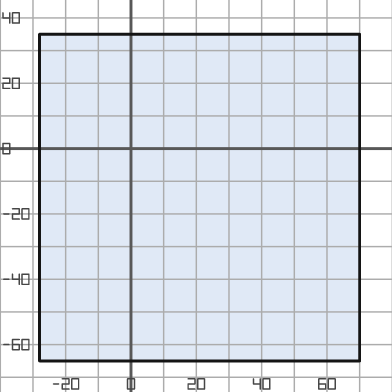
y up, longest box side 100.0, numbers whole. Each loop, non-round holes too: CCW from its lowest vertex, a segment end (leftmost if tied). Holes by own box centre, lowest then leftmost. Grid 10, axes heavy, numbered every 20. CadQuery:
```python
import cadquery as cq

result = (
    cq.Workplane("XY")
    .moveTo(-28.0, -65.0)
    .lineTo(70.0, -65.0)
    .lineTo(70.0, 35.0)
    .lineTo(-28.0, 35.0)
    .close()
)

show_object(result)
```